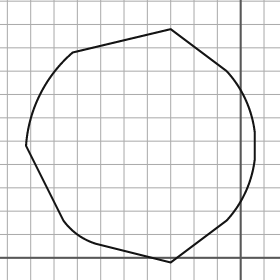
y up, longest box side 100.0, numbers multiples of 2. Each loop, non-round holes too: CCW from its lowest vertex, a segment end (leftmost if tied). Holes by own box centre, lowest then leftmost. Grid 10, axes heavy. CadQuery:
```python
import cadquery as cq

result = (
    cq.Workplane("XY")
    .moveTo(-30.0, -2.0)
    .lineTo(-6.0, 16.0)
    .threePointArc((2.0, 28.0), (6.0, 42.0))
    .lineTo(6.0, 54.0)
    .threePointArc((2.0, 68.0), (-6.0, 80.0))
    .lineTo(-30.0, 98.0)
    .lineTo(-72.0, 88.0)
    .threePointArc((-86.0, 70.0), (-92.0, 48.0))
    .lineTo(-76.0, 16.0)
    .threePointArc((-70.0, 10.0), (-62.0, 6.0))
    .close()
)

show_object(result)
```